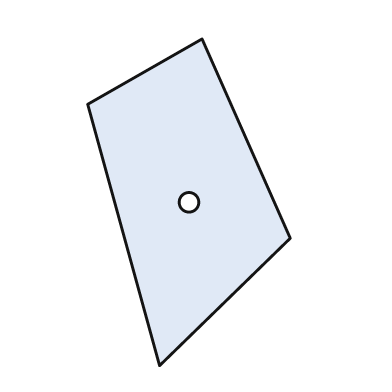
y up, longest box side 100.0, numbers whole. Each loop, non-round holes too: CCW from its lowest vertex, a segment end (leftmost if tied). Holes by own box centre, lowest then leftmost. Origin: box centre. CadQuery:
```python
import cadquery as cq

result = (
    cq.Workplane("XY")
    .moveTo(-9.0, -50.0)
    .lineTo(31.0, -11.0)
    .lineTo(4.0, 50.0)
    .lineTo(-31.0, 30.0)
    .close()
    .moveTo(0.0, 0.0)
    .circle(3.0)
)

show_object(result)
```